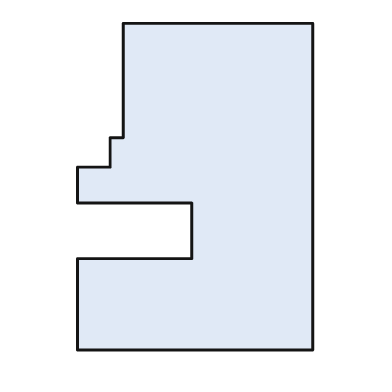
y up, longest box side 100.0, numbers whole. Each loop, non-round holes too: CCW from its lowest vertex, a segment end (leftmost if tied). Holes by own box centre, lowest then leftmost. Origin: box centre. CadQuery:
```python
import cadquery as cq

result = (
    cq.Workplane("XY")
    .moveTo(-36.0, -50.0)
    .lineTo(36.0, -50.0)
    .lineTo(36.0, 50.0)
    .lineTo(-22.0, 50.0)
    .lineTo(-22.0, 15.0)
    .lineTo(-26.0, 15.0)
    .lineTo(-26.0, 6.0)
    .lineTo(-36.0, 6.0)
    .lineTo(-36.0, -5.0)
    .lineTo(-1.0, -5.0)
    .lineTo(-1.0, -22.0)
    .lineTo(-36.0, -22.0)
    .close()
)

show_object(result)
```